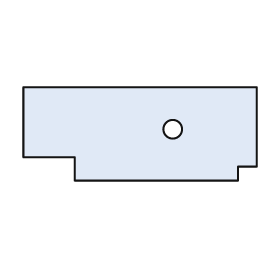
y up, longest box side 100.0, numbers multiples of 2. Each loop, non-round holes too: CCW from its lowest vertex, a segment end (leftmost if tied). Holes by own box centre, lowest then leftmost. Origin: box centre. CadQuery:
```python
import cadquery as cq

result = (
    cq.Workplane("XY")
    .moveTo(-28.0, -20.0)
    .lineTo(42.0, -20.0)
    .lineTo(42.0, -14.0)
    .lineTo(50.0, -14.0)
    .lineTo(50.0, 20.0)
    .lineTo(-50.0, 20.0)
    .lineTo(-50.0, -10.0)
    .lineTo(-28.0, -10.0)
    .close()
    .moveTo(14.0, 2.0)
    .circle(4.0)
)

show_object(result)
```